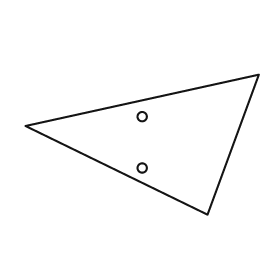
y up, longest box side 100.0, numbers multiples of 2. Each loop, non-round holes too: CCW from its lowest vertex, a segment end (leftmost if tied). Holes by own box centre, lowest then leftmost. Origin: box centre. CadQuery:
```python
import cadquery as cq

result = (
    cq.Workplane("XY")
    .moveTo(28.0, -30.0)
    .lineTo(50.0, 30.0)
    .lineTo(-50.0, 8.0)
    .close()
    .moveTo(0.0, -10.0)
    .circle(2.0)
    .moveTo(0.0, 12.0)
    .circle(2.0)
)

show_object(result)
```